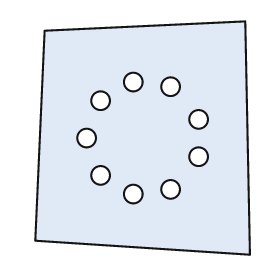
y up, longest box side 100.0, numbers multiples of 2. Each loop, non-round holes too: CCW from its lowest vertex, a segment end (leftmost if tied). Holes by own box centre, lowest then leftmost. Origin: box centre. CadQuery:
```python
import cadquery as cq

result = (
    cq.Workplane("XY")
    .moveTo(46.0, -50.0)
    .lineTo(44.0, 50.0)
    .lineTo(-42.0, 46.0)
    .lineTo(-46.0, -44.0)
    .close()
    .moveTo(-4.0, -24.0)
    .circle(4.0)
    .moveTo(12.0, -22.0)
    .circle(4.0)
    .moveTo(-18.0, -16.0)
    .circle(4.0)
    .moveTo(24.0, -8.0)
    .circle(4.0)
    .moveTo(-24.0, 0.0)
    .circle(4.0)
    .moveTo(24.0, 8.0)
    .circle(4.0)
    .moveTo(-18.0, 16.0)
    .circle(4.0)
    .moveTo(12.0, 22.0)
    .circle(4.0)
    .moveTo(-4.0, 24.0)
    .circle(4.0)
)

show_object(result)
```